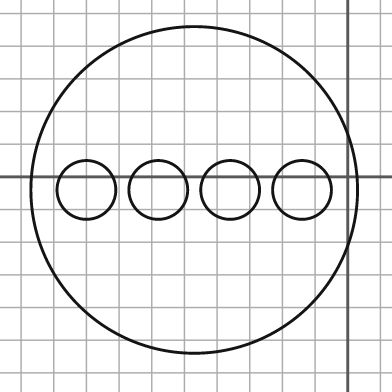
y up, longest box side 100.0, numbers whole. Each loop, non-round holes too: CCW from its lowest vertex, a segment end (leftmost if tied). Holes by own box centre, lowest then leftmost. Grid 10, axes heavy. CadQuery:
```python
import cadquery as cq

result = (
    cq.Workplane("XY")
    .moveTo(-47.0, -4.0)
    .circle(50.0)
    .moveTo(-80.0, -4.0)
    .circle(9.0)
    .moveTo(-58.0, -4.0)
    .circle(9.0)
    .moveTo(-36.0, -4.0)
    .circle(9.0)
    .moveTo(-14.0, -4.0)
    .circle(9.0)
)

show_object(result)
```